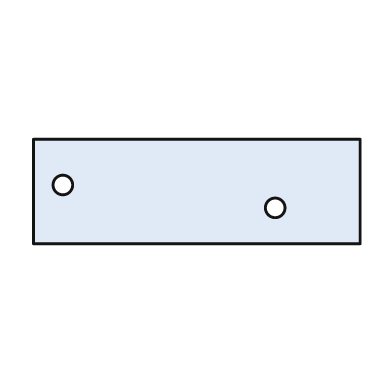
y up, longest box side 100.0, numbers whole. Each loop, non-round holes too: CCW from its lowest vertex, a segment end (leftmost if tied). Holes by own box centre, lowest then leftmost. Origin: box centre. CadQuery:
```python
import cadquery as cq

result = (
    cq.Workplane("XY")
    .moveTo(-50.0, -16.0)
    .lineTo(50.0, -16.0)
    .lineTo(50.0, 16.0)
    .lineTo(-50.0, 16.0)
    .close()
    .moveTo(24.0, -5.0)
    .circle(3.0)
    .moveTo(-41.0, 2.0)
    .circle(3.0)
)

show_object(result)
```